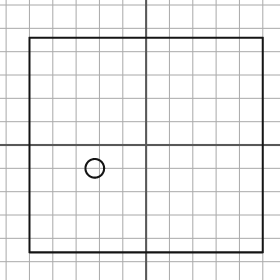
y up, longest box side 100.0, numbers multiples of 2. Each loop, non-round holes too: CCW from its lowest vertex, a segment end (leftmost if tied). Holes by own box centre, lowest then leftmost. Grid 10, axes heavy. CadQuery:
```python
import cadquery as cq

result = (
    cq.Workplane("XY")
    .moveTo(-50.0, -46.0)
    .lineTo(50.0, -46.0)
    .lineTo(50.0, 46.0)
    .lineTo(-50.0, 46.0)
    .close()
    .moveTo(-22.0, -10.0)
    .circle(4.0)
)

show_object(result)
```